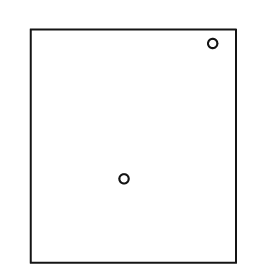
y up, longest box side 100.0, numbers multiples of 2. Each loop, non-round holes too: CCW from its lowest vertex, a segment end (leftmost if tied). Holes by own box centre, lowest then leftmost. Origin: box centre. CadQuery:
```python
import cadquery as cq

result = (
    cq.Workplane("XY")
    .moveTo(-44.0, -50.0)
    .lineTo(44.0, -50.0)
    .lineTo(44.0, 50.0)
    .lineTo(-44.0, 50.0)
    .close()
    .moveTo(-4.0, -14.0)
    .circle(2.0)
    .moveTo(34.0, 44.0)
    .circle(2.0)
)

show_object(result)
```